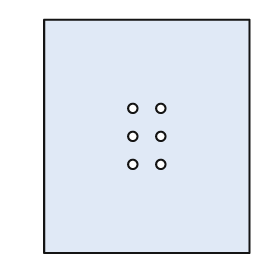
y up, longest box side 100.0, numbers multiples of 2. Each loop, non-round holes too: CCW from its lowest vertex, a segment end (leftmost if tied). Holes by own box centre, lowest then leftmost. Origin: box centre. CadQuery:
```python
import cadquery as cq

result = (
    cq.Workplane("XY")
    .moveTo(-44.0, -50.0)
    .lineTo(44.0, -50.0)
    .lineTo(44.0, 50.0)
    .lineTo(-44.0, 50.0)
    .close()
    .moveTo(-6.0, -12.0)
    .circle(2.0)
    .moveTo(6.0, -12.0)
    .circle(2.0)
    .moveTo(-6.0, 0.0)
    .circle(2.0)
    .moveTo(6.0, 0.0)
    .circle(2.0)
    .moveTo(-6.0, 12.0)
    .circle(2.0)
    .moveTo(6.0, 12.0)
    .circle(2.0)
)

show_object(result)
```